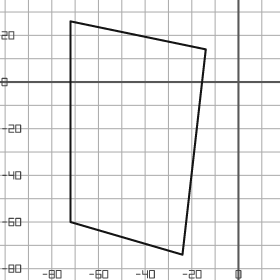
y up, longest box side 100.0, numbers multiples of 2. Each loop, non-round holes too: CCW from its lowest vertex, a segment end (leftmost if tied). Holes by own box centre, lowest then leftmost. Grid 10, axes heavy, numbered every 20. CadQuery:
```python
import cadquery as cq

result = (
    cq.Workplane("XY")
    .moveTo(-24.0, -74.0)
    .lineTo(-14.0, 14.0)
    .lineTo(-72.0, 26.0)
    .lineTo(-72.0, -60.0)
    .close()
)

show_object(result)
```